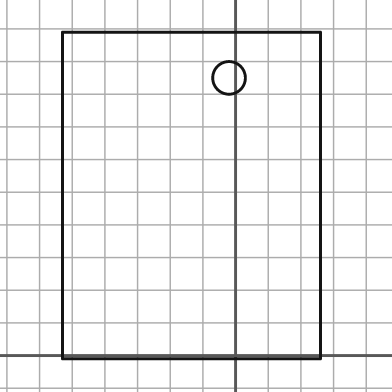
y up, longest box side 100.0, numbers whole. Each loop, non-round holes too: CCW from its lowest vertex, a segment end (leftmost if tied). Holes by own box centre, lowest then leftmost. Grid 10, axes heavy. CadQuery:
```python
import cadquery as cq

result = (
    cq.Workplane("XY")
    .moveTo(-53.0, -1.0)
    .lineTo(26.0, -1.0)
    .lineTo(26.0, 99.0)
    .lineTo(-53.0, 99.0)
    .close()
    .moveTo(-2.0, 85.0)
    .circle(5.0)
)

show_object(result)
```